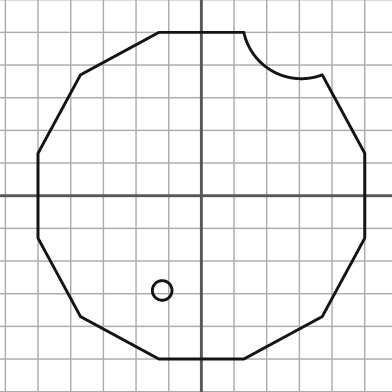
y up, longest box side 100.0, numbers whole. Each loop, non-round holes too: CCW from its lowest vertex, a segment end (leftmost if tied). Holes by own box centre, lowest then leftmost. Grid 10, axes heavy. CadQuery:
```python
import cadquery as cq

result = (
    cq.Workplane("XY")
    .moveTo(-13.0, -50.0)
    .lineTo(13.0, -50.0)
    .lineTo(37.0, -37.0)
    .lineTo(50.0, -13.0)
    .lineTo(50.0, 13.0)
    .lineTo(37.0, 37.0)
    .threePointArc((22.0, 38.0), (13.0, 50.0))
    .lineTo(-13.0, 50.0)
    .lineTo(-37.0, 37.0)
    .lineTo(-50.0, 13.0)
    .lineTo(-50.0, -13.0)
    .lineTo(-37.0, -37.0)
    .close()
    .moveTo(-12.0, -29.0)
    .circle(3.0)
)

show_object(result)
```